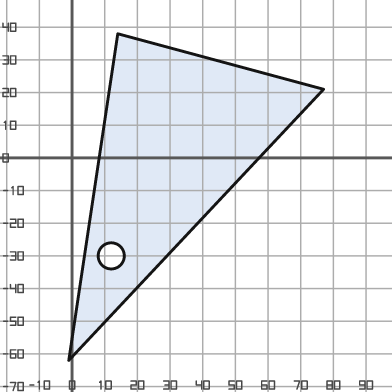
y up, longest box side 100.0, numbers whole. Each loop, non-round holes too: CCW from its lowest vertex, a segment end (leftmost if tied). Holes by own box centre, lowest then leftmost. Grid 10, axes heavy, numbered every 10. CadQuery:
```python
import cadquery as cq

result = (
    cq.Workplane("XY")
    .moveTo(-1.0, -62.0)
    .lineTo(77.0, 21.0)
    .lineTo(14.0, 38.0)
    .close()
    .moveTo(12.0, -30.0)
    .circle(4.0)
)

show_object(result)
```